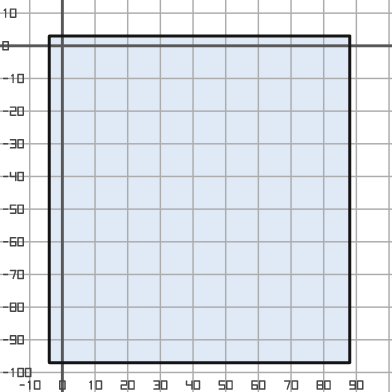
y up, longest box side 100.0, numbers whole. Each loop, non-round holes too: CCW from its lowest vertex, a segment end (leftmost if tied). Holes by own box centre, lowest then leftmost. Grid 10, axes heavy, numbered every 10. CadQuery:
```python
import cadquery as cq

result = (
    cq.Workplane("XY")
    .moveTo(-4.0, -97.0)
    .lineTo(88.0, -97.0)
    .lineTo(88.0, 3.0)
    .lineTo(-4.0, 3.0)
    .close()
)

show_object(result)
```